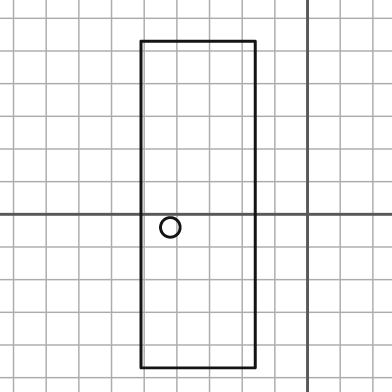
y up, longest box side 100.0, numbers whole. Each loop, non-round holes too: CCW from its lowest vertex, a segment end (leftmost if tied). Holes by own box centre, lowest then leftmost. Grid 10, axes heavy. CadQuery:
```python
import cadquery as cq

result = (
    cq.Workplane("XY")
    .moveTo(-51.0, -47.0)
    .lineTo(-16.0, -47.0)
    .lineTo(-16.0, 53.0)
    .lineTo(-51.0, 53.0)
    .close()
    .moveTo(-42.0, -4.0)
    .circle(3.0)
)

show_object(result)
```